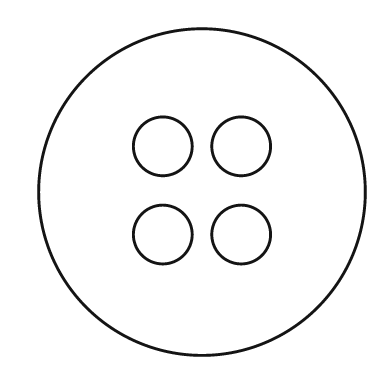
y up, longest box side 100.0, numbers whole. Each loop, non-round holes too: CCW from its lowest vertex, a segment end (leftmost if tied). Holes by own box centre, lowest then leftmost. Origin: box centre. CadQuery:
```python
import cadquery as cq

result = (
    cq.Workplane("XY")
    .moveTo(0.0, 0.0)
    .circle(50.0)
    .moveTo(-12.0, -13.0)
    .circle(9.0)
    .moveTo(12.0, -13.0)
    .circle(9.0)
    .moveTo(-12.0, 14.0)
    .circle(9.0)
    .moveTo(12.0, 14.0)
    .circle(9.0)
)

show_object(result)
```